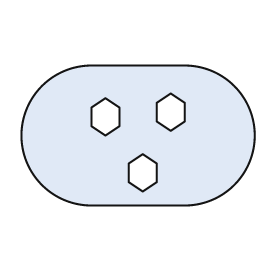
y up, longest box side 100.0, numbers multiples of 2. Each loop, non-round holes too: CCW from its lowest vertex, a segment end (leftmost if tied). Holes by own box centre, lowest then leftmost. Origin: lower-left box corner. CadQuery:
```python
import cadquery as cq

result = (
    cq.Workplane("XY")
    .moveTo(30.0, 0.0)
    .lineTo(70.0, 0.0)
    .threePointArc((100.0, 30.0), (70.0, 60.0))
    .lineTo(30.0, 60.0)
    .threePointArc((0.0, 30.0), (30.0, 0.0))
    .close()
    .moveTo(52.0, 6.0)
    .lineTo(58.0, 10.0)
    .lineTo(58.0, 18.0)
    .lineTo(52.0, 22.0)
    .lineTo(46.0, 18.0)
    .lineTo(46.0, 10.0)
    .close()
    .moveTo(36.0, 30.0)
    .lineTo(42.0, 34.0)
    .lineTo(42.0, 42.0)
    .lineTo(36.0, 46.0)
    .lineTo(30.0, 42.0)
    .lineTo(30.0, 34.0)
    .close()
    .moveTo(64.0, 32.0)
    .lineTo(70.0, 36.0)
    .lineTo(70.0, 44.0)
    .lineTo(64.0, 48.0)
    .lineTo(58.0, 44.0)
    .lineTo(58.0, 36.0)
    .close()
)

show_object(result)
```